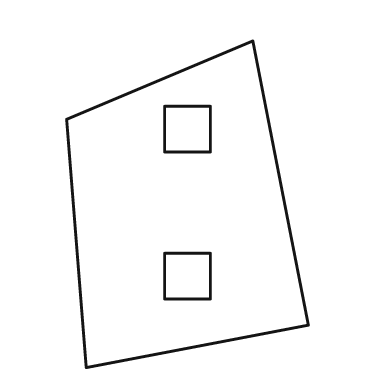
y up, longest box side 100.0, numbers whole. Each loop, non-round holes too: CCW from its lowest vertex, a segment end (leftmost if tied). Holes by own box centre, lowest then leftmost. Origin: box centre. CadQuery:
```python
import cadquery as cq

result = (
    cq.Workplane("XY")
    .moveTo(-31.0, -50.0)
    .lineTo(37.0, -37.0)
    .lineTo(20.0, 50.0)
    .lineTo(-37.0, 26.0)
    .close()
    .moveTo(-7.0, -29.0)
    .lineTo(7.0, -29.0)
    .lineTo(7.0, -15.0)
    .lineTo(-7.0, -15.0)
    .close()
    .moveTo(-7.0, 16.0)
    .lineTo(7.0, 16.0)
    .lineTo(7.0, 30.0)
    .lineTo(-7.0, 30.0)
    .close()
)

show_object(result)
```